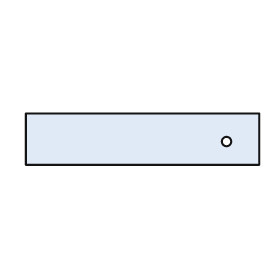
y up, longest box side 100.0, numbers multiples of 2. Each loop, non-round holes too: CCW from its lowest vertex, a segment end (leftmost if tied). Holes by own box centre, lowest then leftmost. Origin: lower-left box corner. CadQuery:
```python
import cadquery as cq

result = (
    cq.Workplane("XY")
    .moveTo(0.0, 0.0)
    .lineTo(100.0, 0.0)
    .lineTo(100.0, 22.0)
    .lineTo(0.0, 22.0)
    .close()
    .moveTo(86.0, 10.0)
    .circle(2.0)
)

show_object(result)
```